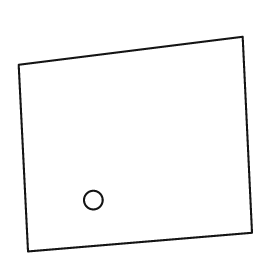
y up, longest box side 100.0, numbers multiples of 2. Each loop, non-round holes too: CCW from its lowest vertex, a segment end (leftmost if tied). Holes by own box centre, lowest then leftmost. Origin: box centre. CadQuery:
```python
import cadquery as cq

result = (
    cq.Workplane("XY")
    .moveTo(-46.0, -46.0)
    .lineTo(50.0, -38.0)
    .lineTo(46.0, 46.0)
    .lineTo(-50.0, 34.0)
    .close()
    .moveTo(-18.0, -24.0)
    .circle(4.0)
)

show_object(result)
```